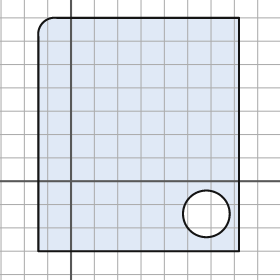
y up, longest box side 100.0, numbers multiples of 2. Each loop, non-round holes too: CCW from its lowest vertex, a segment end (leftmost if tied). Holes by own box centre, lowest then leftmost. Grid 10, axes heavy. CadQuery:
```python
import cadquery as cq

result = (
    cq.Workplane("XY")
    .moveTo(-14.0, -30.0)
    .lineTo(72.0, -30.0)
    .lineTo(72.0, 70.0)
    .lineTo(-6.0, 70.0)
    .threePointArc((-12.0, 68.0), (-14.0, 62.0))
    .close()
    .moveTo(58.0, -14.0)
    .circle(10.0)
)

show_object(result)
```